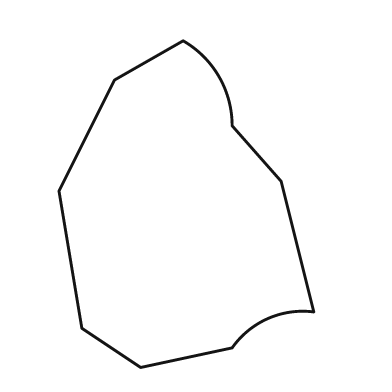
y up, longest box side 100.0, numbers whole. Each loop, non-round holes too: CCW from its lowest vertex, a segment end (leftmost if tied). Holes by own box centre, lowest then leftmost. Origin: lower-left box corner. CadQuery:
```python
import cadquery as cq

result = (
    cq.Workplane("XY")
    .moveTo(25.0, 0.0)
    .lineTo(53.0, 6.0)
    .threePointArc((64.0, 15.0), (78.0, 17.0))
    .lineTo(68.0, 57.0)
    .lineTo(53.0, 74.0)
    .threePointArc((49.0, 89.0), (38.0, 100.0))
    .lineTo(17.0, 88.0)
    .lineTo(0.0, 54.0)
    .lineTo(7.0, 12.0)
    .close()
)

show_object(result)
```